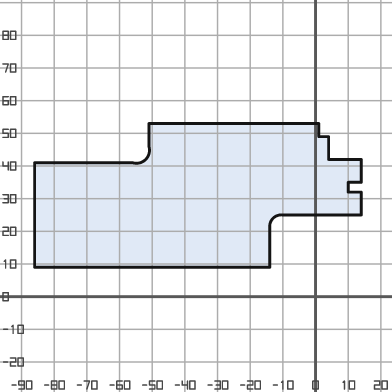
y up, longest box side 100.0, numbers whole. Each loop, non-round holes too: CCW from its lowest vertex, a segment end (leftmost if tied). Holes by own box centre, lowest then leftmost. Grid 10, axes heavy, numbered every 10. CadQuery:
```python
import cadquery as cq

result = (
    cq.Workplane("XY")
    .moveTo(-86.0, 9.0)
    .lineTo(-14.0, 9.0)
    .lineTo(-14.0, 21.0)
    .threePointArc((-13.0, 24.0), (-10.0, 25.0))
    .lineTo(14.0, 25.0)
    .lineTo(14.0, 32.0)
    .lineTo(10.0, 32.0)
    .lineTo(10.0, 35.0)
    .lineTo(14.0, 35.0)
    .lineTo(14.0, 42.0)
    .lineTo(4.0, 42.0)
    .lineTo(4.0, 49.0)
    .lineTo(1.0, 49.0)
    .lineTo(1.0, 53.0)
    .lineTo(-51.0, 53.0)
    .lineTo(-51.0, 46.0)
    .threePointArc((-52.0, 42.0), (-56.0, 41.0))
    .lineTo(-86.0, 41.0)
    .close()
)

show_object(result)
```